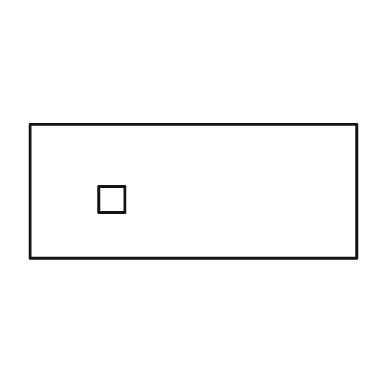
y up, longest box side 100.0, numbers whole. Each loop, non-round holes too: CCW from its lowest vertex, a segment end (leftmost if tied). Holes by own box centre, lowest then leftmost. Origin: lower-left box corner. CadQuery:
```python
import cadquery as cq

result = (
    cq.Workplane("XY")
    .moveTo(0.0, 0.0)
    .lineTo(100.0, 0.0)
    .lineTo(100.0, 41.0)
    .lineTo(0.0, 41.0)
    .close()
    .moveTo(21.0, 14.0)
    .lineTo(29.0, 14.0)
    .lineTo(29.0, 22.0)
    .lineTo(21.0, 22.0)
    .close()
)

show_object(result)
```